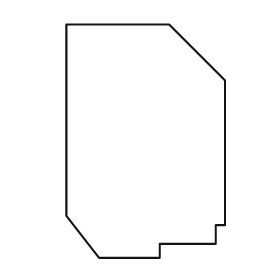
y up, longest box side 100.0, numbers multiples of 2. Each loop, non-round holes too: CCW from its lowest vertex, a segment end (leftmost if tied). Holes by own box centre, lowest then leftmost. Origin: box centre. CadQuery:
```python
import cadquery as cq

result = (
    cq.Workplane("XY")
    .moveTo(-20.0, -50.0)
    .lineTo(6.0, -50.0)
    .lineTo(6.0, -44.0)
    .lineTo(30.0, -44.0)
    .lineTo(30.0, -36.0)
    .lineTo(34.0, -36.0)
    .lineTo(34.0, 26.0)
    .lineTo(10.0, 50.0)
    .lineTo(-34.0, 50.0)
    .lineTo(-34.0, -32.0)
    .close()
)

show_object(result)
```